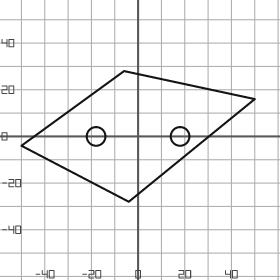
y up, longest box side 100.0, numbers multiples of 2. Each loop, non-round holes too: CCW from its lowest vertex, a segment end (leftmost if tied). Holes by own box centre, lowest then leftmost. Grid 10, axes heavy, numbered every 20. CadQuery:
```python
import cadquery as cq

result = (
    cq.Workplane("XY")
    .moveTo(-4.0, -28.0)
    .lineTo(50.0, 16.0)
    .lineTo(-6.0, 28.0)
    .lineTo(-50.0, -4.0)
    .close()
    .moveTo(-18.0, 0.0)
    .circle(4.0)
    .moveTo(18.0, 0.0)
    .circle(4.0)
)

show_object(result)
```